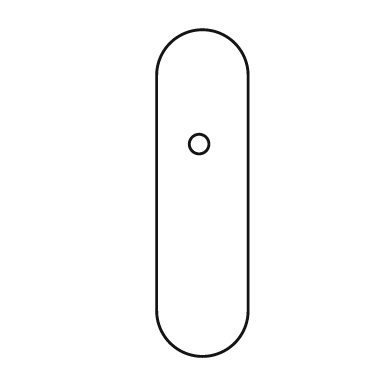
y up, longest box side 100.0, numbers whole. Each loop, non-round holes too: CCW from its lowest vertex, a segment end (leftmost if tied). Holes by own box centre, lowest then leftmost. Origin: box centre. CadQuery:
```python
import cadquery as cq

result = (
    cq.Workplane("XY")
    .moveTo(-14.0, -36.0)
    .threePointArc((0.0, -50.0), (14.0, -36.0))
    .lineTo(14.0, 36.0)
    .threePointArc((0.0, 50.0), (-14.0, 36.0))
    .close()
    .moveTo(-1.0, 15.0)
    .circle(3.0)
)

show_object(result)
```